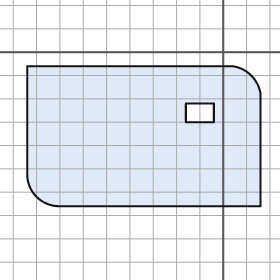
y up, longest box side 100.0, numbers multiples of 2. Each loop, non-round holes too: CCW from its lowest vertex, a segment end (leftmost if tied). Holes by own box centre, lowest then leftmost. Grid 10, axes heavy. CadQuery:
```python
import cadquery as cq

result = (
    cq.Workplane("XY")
    .moveTo(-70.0, -66.0)
    .lineTo(16.0, -66.0)
    .lineTo(16.0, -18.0)
    .threePointArc((12.0, -10.0), (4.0, -6.0))
    .lineTo(-84.0, -6.0)
    .lineTo(-84.0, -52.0)
    .threePointArc((-80.0, -62.0), (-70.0, -66.0))
    .close()
    .moveTo(-16.0, -30.0)
    .lineTo(-4.0, -30.0)
    .lineTo(-4.0, -22.0)
    .lineTo(-16.0, -22.0)
    .close()
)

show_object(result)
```